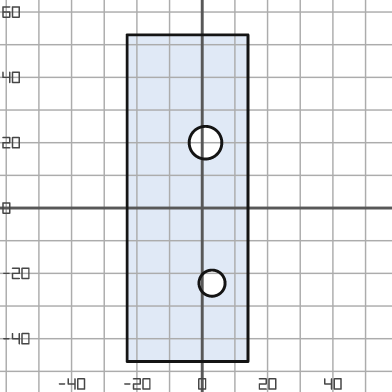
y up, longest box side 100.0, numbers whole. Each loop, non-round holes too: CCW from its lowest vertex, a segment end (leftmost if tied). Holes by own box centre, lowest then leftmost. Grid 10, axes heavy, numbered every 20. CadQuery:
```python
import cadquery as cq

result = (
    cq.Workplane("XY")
    .moveTo(-23.0, -47.0)
    .lineTo(14.0, -47.0)
    .lineTo(14.0, 53.0)
    .lineTo(-23.0, 53.0)
    .close()
    .moveTo(3.0, -23.0)
    .circle(4.0)
    .moveTo(1.0, 20.0)
    .circle(5.0)
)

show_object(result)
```